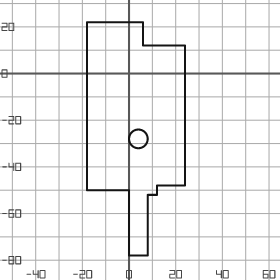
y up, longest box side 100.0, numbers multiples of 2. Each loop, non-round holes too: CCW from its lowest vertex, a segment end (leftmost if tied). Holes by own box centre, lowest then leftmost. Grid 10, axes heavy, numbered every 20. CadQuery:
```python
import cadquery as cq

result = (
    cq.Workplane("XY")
    .moveTo(0.0, -78.0)
    .lineTo(8.0, -78.0)
    .lineTo(8.0, -52.0)
    .lineTo(12.0, -52.0)
    .lineTo(12.0, -48.0)
    .lineTo(24.0, -48.0)
    .lineTo(24.0, 12.0)
    .lineTo(6.0, 12.0)
    .lineTo(6.0, 22.0)
    .lineTo(-18.0, 22.0)
    .lineTo(-18.0, -50.0)
    .lineTo(0.0, -50.0)
    .close()
    .moveTo(4.0, -28.0)
    .circle(4.0)
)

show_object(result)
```